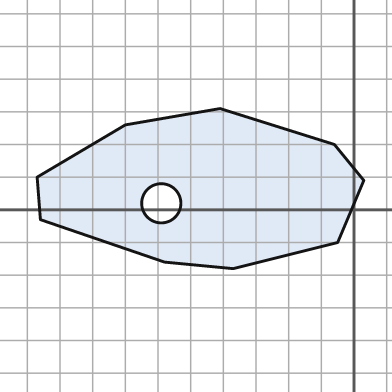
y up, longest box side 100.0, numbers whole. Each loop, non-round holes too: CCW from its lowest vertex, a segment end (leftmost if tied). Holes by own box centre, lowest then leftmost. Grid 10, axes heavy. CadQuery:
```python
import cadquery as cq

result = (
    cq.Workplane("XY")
    .moveTo(-37.0, -18.0)
    .lineTo(-5.0, -10.0)
    .lineTo(3.0, 9.0)
    .lineTo(-6.0, 20.0)
    .lineTo(-41.0, 31.0)
    .lineTo(-70.0, 26.0)
    .lineTo(-97.0, 10.0)
    .lineTo(-96.0, -3.0)
    .lineTo(-58.0, -16.0)
    .close()
    .moveTo(-59.0, 2.0)
    .circle(6.0)
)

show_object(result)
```